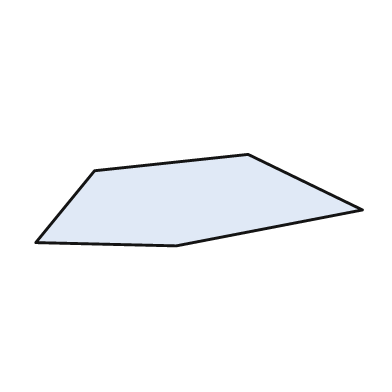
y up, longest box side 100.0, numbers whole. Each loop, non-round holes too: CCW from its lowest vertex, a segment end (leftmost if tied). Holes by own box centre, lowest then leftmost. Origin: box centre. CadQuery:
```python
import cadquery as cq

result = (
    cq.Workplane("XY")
    .moveTo(-7.0, -14.0)
    .lineTo(50.0, -3.0)
    .lineTo(15.0, 14.0)
    .lineTo(-32.0, 9.0)
    .lineTo(-50.0, -13.0)
    .close()
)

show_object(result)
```